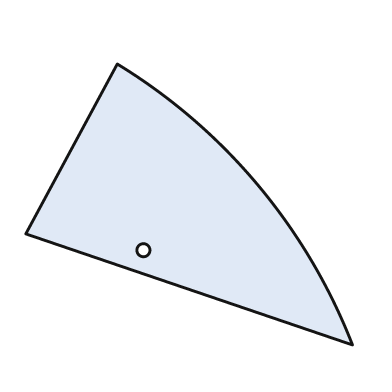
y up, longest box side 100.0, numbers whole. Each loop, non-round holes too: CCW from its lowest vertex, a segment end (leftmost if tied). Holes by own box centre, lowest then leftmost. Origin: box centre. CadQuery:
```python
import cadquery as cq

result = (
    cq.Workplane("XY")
    .moveTo(50.0, -43.0)
    .threePointArc((21.0, 6.0), (-22.0, 43.0))
    .lineTo(-50.0, -9.0)
    .close()
    .moveTo(-14.0, -14.0)
    .circle(2.0)
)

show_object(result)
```